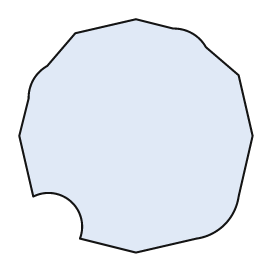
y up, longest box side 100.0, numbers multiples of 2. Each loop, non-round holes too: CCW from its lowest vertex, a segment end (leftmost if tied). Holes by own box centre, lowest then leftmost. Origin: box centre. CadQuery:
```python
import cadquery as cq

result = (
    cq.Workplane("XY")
    .moveTo(0.0, -50.0)
    .lineTo(26.0, -44.0)
    .threePointArc((38.0, -38.0), (44.0, -26.0))
    .lineTo(50.0, 0.0)
    .lineTo(44.0, 26.0)
    .lineTo(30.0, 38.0)
    .threePointArc((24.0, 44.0), (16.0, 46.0))
    .lineTo(0.0, 50.0)
    .lineTo(-26.0, 44.0)
    .lineTo(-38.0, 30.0)
    .threePointArc((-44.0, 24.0), (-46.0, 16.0))
    .lineTo(-50.0, 0.0)
    .lineTo(-44.0, -26.0)
    .threePointArc((-28.0, -28.0), (-24.0, -44.0))
    .close()
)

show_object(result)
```